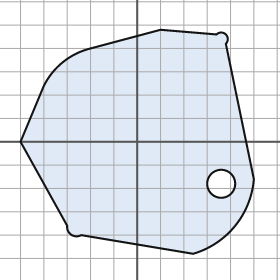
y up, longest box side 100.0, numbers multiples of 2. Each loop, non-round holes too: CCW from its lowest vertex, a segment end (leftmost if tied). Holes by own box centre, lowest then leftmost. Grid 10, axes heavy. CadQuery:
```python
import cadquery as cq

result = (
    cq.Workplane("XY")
    .moveTo(24.0, -48.0)
    .threePointArc((42.0, -36.0), (50.0, -16.0))
    .lineTo(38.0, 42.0)
    .threePointArc((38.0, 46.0), (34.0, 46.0))
    .lineTo(10.0, 48.0)
    .lineTo(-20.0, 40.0)
    .threePointArc((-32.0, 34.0), (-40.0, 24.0))
    .lineTo(-50.0, 0.0)
    .lineTo(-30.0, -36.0)
    .threePointArc((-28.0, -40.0), (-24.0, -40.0))
    .close()
    .moveTo(36.0, -18.0)
    .circle(6.0)
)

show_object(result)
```